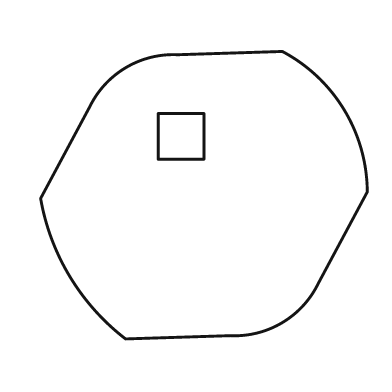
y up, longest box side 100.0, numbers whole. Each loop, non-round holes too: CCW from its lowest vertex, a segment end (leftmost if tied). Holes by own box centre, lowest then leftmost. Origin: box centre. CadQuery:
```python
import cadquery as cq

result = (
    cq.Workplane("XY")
    .moveTo(-24.0, -44.0)
    .lineTo(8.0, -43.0)
    .threePointArc((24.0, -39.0), (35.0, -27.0))
    .lineTo(50.0, 1.0)
    .threePointArc((43.0, 26.0), (24.0, 44.0))
    .lineTo(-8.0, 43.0)
    .threePointArc((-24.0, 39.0), (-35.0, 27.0))
    .lineTo(-50.0, -1.0)
    .threePointArc((-41.0, -25.0), (-24.0, -44.0))
    .close()
    .moveTo(-14.0, 11.0)
    .lineTo(0.0, 11.0)
    .lineTo(0.0, 25.0)
    .lineTo(-14.0, 25.0)
    .close()
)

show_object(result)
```